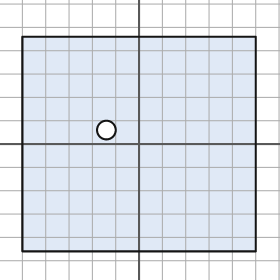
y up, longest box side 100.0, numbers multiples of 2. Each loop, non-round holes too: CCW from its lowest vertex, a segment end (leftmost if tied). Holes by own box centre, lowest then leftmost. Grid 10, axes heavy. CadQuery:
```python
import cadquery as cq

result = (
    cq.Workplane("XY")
    .moveTo(-50.0, -46.0)
    .lineTo(50.0, -46.0)
    .lineTo(50.0, 46.0)
    .lineTo(-50.0, 46.0)
    .close()
    .moveTo(-14.0, 6.0)
    .circle(4.0)
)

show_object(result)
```